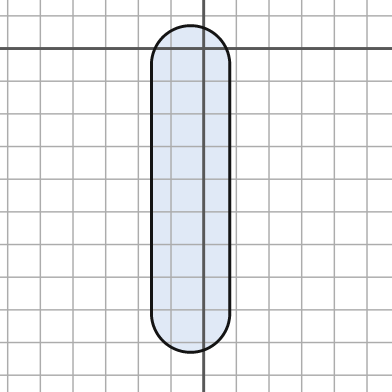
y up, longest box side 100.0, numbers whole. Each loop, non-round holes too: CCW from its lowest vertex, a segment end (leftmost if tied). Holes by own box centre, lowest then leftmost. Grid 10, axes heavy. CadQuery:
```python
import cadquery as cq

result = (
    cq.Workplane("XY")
    .moveTo(-16.0, -81.0)
    .threePointArc((-4.0, -93.0), (8.0, -81.0))
    .lineTo(8.0, -5.0)
    .threePointArc((-4.0, 7.0), (-16.0, -5.0))
    .close()
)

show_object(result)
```